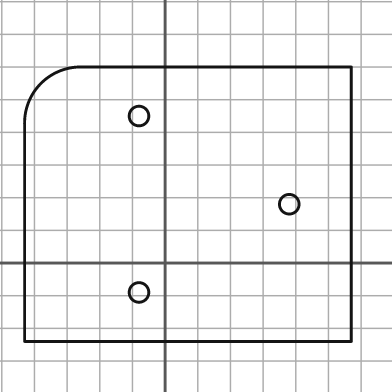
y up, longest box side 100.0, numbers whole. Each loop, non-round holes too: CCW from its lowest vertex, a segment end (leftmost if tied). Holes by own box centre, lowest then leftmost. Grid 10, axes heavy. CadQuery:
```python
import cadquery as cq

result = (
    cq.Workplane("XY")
    .moveTo(-43.0, -24.0)
    .lineTo(57.0, -24.0)
    .lineTo(57.0, 60.0)
    .lineTo(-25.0, 60.0)
    .threePointArc((-38.0, 55.0), (-43.0, 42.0))
    .close()
    .moveTo(-8.0, -9.0)
    .circle(3.0)
    .moveTo(38.0, 18.0)
    .circle(3.0)
    .moveTo(-8.0, 45.0)
    .circle(3.0)
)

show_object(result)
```